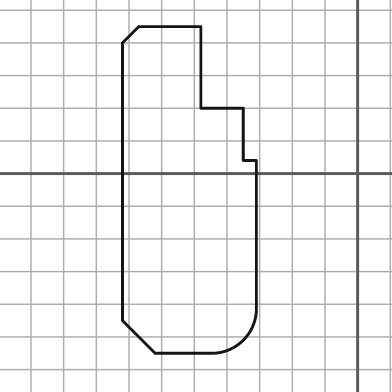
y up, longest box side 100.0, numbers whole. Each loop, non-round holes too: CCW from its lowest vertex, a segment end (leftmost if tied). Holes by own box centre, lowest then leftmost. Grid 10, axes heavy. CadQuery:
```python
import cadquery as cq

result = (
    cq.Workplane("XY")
    .moveTo(-62.0, -55.0)
    .lineTo(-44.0, -55.0)
    .threePointArc((-35.0, -51.0), (-31.0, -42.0))
    .lineTo(-31.0, 4.0)
    .lineTo(-35.0, 4.0)
    .lineTo(-35.0, 20.0)
    .lineTo(-48.0, 20.0)
    .lineTo(-48.0, 45.0)
    .lineTo(-67.0, 45.0)
    .lineTo(-72.0, 40.0)
    .lineTo(-72.0, -45.0)
    .close()
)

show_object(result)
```